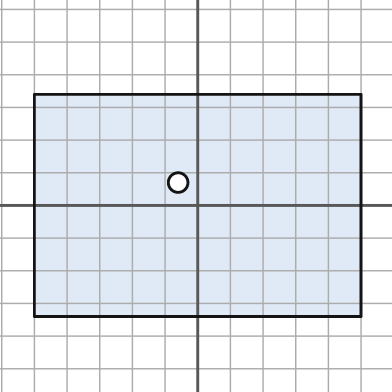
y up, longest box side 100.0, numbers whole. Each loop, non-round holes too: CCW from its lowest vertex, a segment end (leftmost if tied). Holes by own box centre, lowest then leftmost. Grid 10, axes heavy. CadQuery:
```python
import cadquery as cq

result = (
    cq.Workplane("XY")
    .moveTo(-50.0, -34.0)
    .lineTo(50.0, -34.0)
    .lineTo(50.0, 34.0)
    .lineTo(-50.0, 34.0)
    .close()
    .moveTo(-6.0, 7.0)
    .circle(3.0)
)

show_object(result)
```